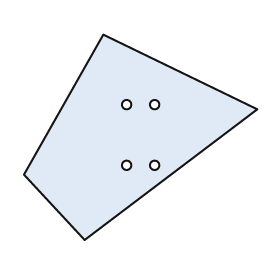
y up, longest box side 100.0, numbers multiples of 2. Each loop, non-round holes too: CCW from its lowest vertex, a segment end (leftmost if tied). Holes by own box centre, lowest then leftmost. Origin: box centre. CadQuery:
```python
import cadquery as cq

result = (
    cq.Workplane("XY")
    .moveTo(-24.0, -44.0)
    .lineTo(50.0, 12.0)
    .lineTo(-16.0, 44.0)
    .lineTo(-50.0, -16.0)
    .close()
    .moveTo(-6.0, -12.0)
    .circle(2.0)
    .moveTo(6.0, -12.0)
    .circle(2.0)
    .moveTo(-6.0, 14.0)
    .circle(2.0)
    .moveTo(6.0, 14.0)
    .circle(2.0)
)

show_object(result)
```